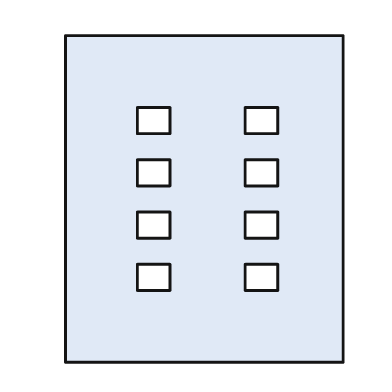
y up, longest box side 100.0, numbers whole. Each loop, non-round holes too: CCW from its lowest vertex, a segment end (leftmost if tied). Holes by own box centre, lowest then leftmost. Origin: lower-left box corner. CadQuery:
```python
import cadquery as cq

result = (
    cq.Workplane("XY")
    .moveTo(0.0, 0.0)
    .lineTo(85.0, 0.0)
    .lineTo(85.0, 100.0)
    .lineTo(0.0, 100.0)
    .close()
    .moveTo(22.0, 22.0)
    .lineTo(32.0, 22.0)
    .lineTo(32.0, 30.0)
    .lineTo(22.0, 30.0)
    .close()
    .moveTo(55.0, 22.0)
    .lineTo(65.0, 22.0)
    .lineTo(65.0, 30.0)
    .lineTo(55.0, 30.0)
    .close()
    .moveTo(22.0, 38.0)
    .lineTo(32.0, 38.0)
    .lineTo(32.0, 46.0)
    .lineTo(22.0, 46.0)
    .close()
    .moveTo(55.0, 38.0)
    .lineTo(65.0, 38.0)
    .lineTo(65.0, 46.0)
    .lineTo(55.0, 46.0)
    .close()
    .moveTo(22.0, 54.0)
    .lineTo(32.0, 54.0)
    .lineTo(32.0, 62.0)
    .lineTo(22.0, 62.0)
    .close()
    .moveTo(55.0, 54.0)
    .lineTo(65.0, 54.0)
    .lineTo(65.0, 62.0)
    .lineTo(55.0, 62.0)
    .close()
    .moveTo(22.0, 70.0)
    .lineTo(32.0, 70.0)
    .lineTo(32.0, 78.0)
    .lineTo(22.0, 78.0)
    .close()
    .moveTo(55.0, 70.0)
    .lineTo(65.0, 70.0)
    .lineTo(65.0, 78.0)
    .lineTo(55.0, 78.0)
    .close()
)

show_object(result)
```